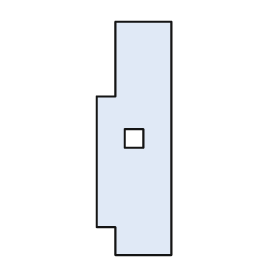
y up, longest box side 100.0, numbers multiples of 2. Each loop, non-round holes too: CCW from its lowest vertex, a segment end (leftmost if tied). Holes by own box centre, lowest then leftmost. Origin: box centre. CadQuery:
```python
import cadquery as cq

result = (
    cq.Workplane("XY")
    .moveTo(-8.0, -50.0)
    .lineTo(16.0, -50.0)
    .lineTo(16.0, 50.0)
    .lineTo(-8.0, 50.0)
    .lineTo(-8.0, 18.0)
    .lineTo(-16.0, 18.0)
    .lineTo(-16.0, -38.0)
    .lineTo(-8.0, -38.0)
    .close()
    .moveTo(-4.0, -4.0)
    .lineTo(4.0, -4.0)
    .lineTo(4.0, 4.0)
    .lineTo(-4.0, 4.0)
    .close()
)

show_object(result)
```